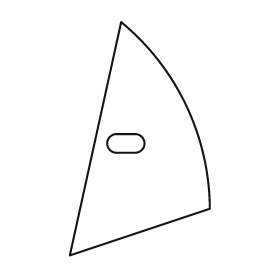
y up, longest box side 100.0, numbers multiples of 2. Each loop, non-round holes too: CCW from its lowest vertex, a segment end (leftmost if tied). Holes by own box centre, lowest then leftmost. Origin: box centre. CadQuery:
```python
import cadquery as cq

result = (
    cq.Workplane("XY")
    .moveTo(-30.0, -50.0)
    .lineTo(30.0, -30.0)
    .threePointArc((20.0, 14.0), (-8.0, 50.0))
    .close()
    .moveTo(-10.0, -6.0)
    .lineTo(-2.0, -6.0)
    .threePointArc((2.0, -2.0), (-2.0, 2.0))
    .lineTo(-10.0, 2.0)
    .threePointArc((-14.0, -2.0), (-10.0, -6.0))
    .close()
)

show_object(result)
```